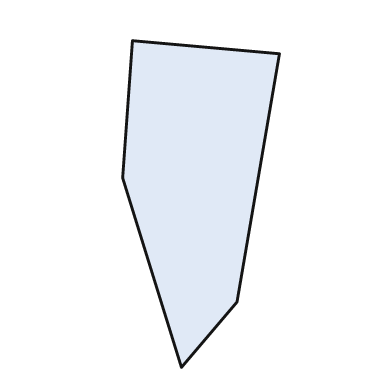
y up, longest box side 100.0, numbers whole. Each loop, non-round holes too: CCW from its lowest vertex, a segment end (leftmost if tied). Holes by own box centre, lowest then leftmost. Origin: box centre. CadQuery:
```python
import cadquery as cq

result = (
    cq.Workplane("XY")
    .moveTo(-6.0, -50.0)
    .lineTo(11.0, -30.0)
    .lineTo(24.0, 46.0)
    .lineTo(-21.0, 50.0)
    .lineTo(-24.0, 8.0)
    .close()
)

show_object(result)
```